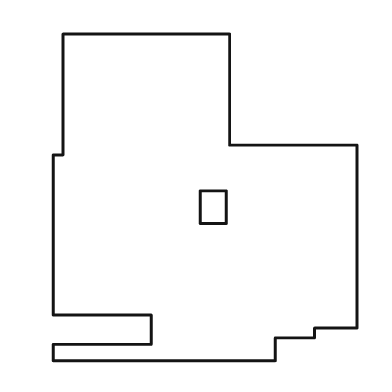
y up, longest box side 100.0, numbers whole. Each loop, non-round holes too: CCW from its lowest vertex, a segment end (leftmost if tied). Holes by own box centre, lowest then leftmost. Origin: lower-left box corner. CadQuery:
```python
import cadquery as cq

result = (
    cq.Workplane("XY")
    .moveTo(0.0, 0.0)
    .lineTo(68.0, 0.0)
    .lineTo(68.0, 7.0)
    .lineTo(80.0, 7.0)
    .lineTo(80.0, 10.0)
    .lineTo(93.0, 10.0)
    .lineTo(93.0, 66.0)
    .lineTo(54.0, 66.0)
    .lineTo(54.0, 100.0)
    .lineTo(3.0, 100.0)
    .lineTo(3.0, 63.0)
    .lineTo(0.0, 63.0)
    .lineTo(0.0, 14.0)
    .lineTo(30.0, 14.0)
    .lineTo(30.0, 5.0)
    .lineTo(0.0, 5.0)
    .close()
    .moveTo(45.0, 42.0)
    .lineTo(53.0, 42.0)
    .lineTo(53.0, 52.0)
    .lineTo(45.0, 52.0)
    .close()
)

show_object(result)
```